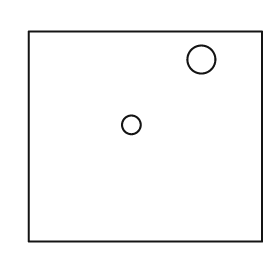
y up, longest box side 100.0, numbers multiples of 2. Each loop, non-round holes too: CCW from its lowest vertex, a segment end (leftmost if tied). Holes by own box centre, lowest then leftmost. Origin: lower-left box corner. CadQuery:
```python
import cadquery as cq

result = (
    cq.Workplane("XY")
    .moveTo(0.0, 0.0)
    .lineTo(100.0, 0.0)
    .lineTo(100.0, 90.0)
    .lineTo(0.0, 90.0)
    .close()
    .moveTo(44.0, 50.0)
    .circle(4.0)
    .moveTo(74.0, 78.0)
    .circle(6.0)
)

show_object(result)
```